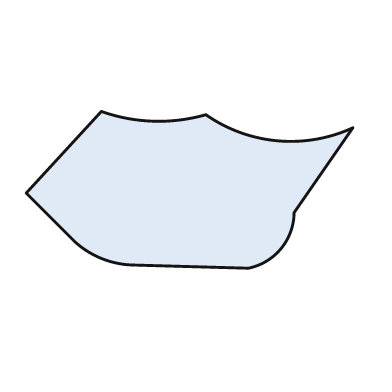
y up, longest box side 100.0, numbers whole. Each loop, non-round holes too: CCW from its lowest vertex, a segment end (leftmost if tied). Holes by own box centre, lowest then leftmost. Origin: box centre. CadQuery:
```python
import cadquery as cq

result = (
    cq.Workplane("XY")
    .moveTo(18.0, -24.0)
    .threePointArc((28.0, -18.0), (32.0, -7.0))
    .lineTo(50.0, 19.0)
    .threePointArc((27.0, 15.0), (5.0, 23.0))
    .threePointArc((-11.0, 21.0), (-27.0, 24.0))
    .lineTo(-50.0, -1.0)
    .lineTo(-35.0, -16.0)
    .threePointArc((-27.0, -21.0), (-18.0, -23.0))
    .close()
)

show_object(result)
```